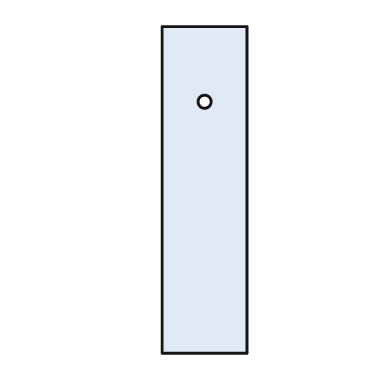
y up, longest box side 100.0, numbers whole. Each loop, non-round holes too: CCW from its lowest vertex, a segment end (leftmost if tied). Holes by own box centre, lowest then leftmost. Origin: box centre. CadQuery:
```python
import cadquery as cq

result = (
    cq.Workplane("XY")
    .moveTo(-13.0, -50.0)
    .lineTo(13.0, -50.0)
    .lineTo(13.0, 50.0)
    .lineTo(-13.0, 50.0)
    .close()
    .moveTo(0.0, 27.0)
    .circle(2.0)
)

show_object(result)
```